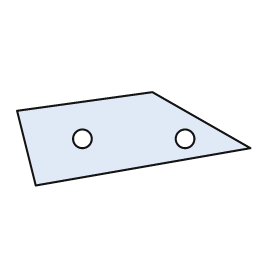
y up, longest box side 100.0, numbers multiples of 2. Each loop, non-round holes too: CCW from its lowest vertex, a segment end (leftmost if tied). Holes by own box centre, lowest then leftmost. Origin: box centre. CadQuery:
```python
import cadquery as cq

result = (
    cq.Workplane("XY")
    .moveTo(-42.0, -20.0)
    .lineTo(50.0, -4.0)
    .lineTo(8.0, 20.0)
    .lineTo(-50.0, 12.0)
    .close()
    .moveTo(-22.0, 0.0)
    .circle(4.0)
    .moveTo(22.0, 0.0)
    .circle(4.0)
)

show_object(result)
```